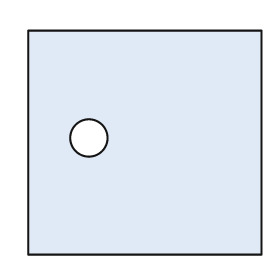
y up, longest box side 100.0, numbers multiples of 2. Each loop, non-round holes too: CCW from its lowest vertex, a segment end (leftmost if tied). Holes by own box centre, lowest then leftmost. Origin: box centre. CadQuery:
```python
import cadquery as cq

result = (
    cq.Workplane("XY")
    .moveTo(-50.0, -48.0)
    .lineTo(50.0, -48.0)
    .lineTo(50.0, 48.0)
    .lineTo(-50.0, 48.0)
    .close()
    .moveTo(-24.0, 2.0)
    .circle(8.0)
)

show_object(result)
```